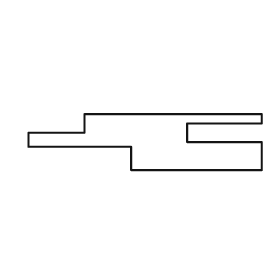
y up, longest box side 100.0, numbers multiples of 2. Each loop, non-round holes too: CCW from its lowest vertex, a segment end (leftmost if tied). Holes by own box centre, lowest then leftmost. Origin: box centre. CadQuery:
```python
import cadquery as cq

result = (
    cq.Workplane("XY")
    .moveTo(-6.0, -12.0)
    .lineTo(50.0, -12.0)
    .lineTo(50.0, 0.0)
    .lineTo(18.0, 0.0)
    .lineTo(18.0, 8.0)
    .lineTo(50.0, 8.0)
    .lineTo(50.0, 12.0)
    .lineTo(-26.0, 12.0)
    .lineTo(-26.0, 4.0)
    .lineTo(-50.0, 4.0)
    .lineTo(-50.0, -2.0)
    .lineTo(-6.0, -2.0)
    .close()
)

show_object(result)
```